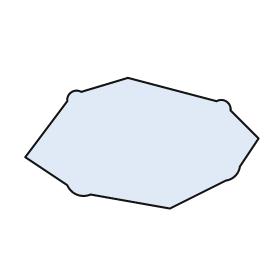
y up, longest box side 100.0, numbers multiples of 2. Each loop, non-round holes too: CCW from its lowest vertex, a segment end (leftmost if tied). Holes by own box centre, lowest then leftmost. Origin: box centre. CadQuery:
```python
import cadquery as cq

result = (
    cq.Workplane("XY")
    .moveTo(12.0, -28.0)
    .lineTo(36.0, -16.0)
    .threePointArc((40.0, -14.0), (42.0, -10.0))
    .lineTo(50.0, 2.0)
    .lineTo(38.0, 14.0)
    .threePointArc((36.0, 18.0), (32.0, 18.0))
    .lineTo(-6.0, 28.0)
    .lineTo(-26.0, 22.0)
    .threePointArc((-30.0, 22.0), (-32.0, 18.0))
    .lineTo(-50.0, -6.0)
    .lineTo(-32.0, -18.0)
    .threePointArc((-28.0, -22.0), (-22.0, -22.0))
    .close()
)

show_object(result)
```